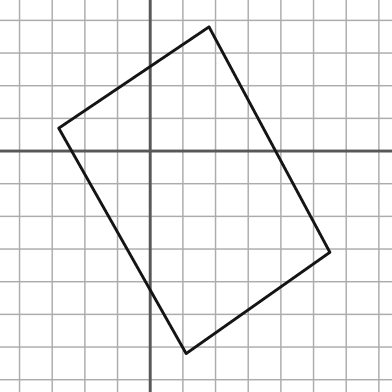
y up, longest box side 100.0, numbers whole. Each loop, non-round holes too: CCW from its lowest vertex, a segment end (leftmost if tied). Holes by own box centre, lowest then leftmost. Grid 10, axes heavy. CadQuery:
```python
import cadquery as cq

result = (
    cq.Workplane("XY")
    .moveTo(11.0, -62.0)
    .lineTo(55.0, -31.0)
    .lineTo(18.0, 38.0)
    .lineTo(-28.0, 7.0)
    .close()
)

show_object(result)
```